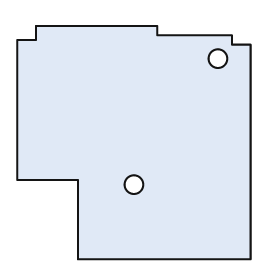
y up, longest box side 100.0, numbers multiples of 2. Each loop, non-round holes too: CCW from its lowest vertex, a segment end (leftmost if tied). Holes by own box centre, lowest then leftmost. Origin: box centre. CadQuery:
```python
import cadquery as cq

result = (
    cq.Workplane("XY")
    .moveTo(-24.0, -50.0)
    .lineTo(50.0, -50.0)
    .lineTo(50.0, 42.0)
    .lineTo(42.0, 42.0)
    .lineTo(42.0, 46.0)
    .lineTo(10.0, 46.0)
    .lineTo(10.0, 50.0)
    .lineTo(-42.0, 50.0)
    .lineTo(-42.0, 44.0)
    .lineTo(-50.0, 44.0)
    .lineTo(-50.0, -16.0)
    .lineTo(-24.0, -16.0)
    .close()
    .moveTo(0.0, -18.0)
    .circle(4.0)
    .moveTo(36.0, 36.0)
    .circle(4.0)
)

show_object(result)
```